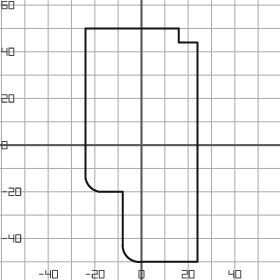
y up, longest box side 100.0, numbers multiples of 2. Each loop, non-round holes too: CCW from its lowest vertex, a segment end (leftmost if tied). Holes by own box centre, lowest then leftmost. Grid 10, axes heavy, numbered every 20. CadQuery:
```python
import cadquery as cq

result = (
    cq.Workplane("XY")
    .moveTo(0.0, -50.0)
    .lineTo(24.0, -50.0)
    .lineTo(24.0, 44.0)
    .lineTo(16.0, 44.0)
    .lineTo(16.0, 50.0)
    .lineTo(-24.0, 50.0)
    .lineTo(-24.0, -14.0)
    .threePointArc((-22.0, -18.0), (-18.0, -20.0))
    .lineTo(-8.0, -20.0)
    .lineTo(-8.0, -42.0)
    .threePointArc((-6.0, -48.0), (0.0, -50.0))
    .close()
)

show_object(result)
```